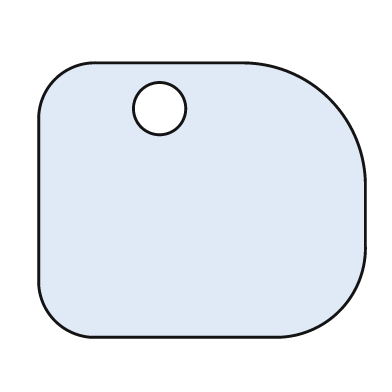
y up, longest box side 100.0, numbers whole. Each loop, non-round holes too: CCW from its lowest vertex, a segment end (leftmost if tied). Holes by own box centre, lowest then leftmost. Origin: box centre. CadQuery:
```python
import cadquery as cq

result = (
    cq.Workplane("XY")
    .moveTo(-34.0, -42.0)
    .lineTo(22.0, -42.0)
    .threePointArc((42.0, -34.0), (50.0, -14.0))
    .lineTo(50.0, 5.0)
    .threePointArc((39.0, 31.0), (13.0, 42.0))
    .lineTo(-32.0, 42.0)
    .threePointArc((-45.0, 37.0), (-50.0, 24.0))
    .lineTo(-50.0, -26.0)
    .threePointArc((-45.0, -37.0), (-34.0, -42.0))
    .close()
    .moveTo(-13.0, 28.0)
    .circle(8.0)
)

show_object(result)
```